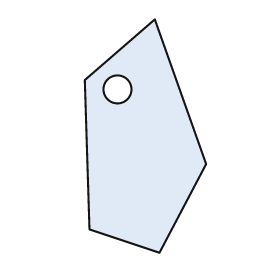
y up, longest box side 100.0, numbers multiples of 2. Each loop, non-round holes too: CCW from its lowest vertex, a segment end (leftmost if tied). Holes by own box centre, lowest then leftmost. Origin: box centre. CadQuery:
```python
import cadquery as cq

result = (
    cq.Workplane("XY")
    .moveTo(6.0, -50.0)
    .lineTo(26.0, -12.0)
    .lineTo(4.0, 50.0)
    .lineTo(-26.0, 24.0)
    .lineTo(-24.0, -40.0)
    .close()
    .moveTo(-12.0, 20.0)
    .circle(6.0)
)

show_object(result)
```